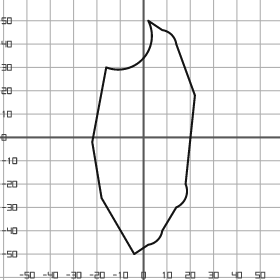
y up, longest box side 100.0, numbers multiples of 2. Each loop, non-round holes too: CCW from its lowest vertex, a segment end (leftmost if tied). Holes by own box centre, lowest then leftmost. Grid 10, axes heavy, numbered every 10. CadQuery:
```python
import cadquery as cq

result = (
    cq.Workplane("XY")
    .moveTo(-4.0, -50.0)
    .lineTo(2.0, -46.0)
    .threePointArc((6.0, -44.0), (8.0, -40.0))
    .lineTo(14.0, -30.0)
    .threePointArc((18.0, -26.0), (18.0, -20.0))
    .lineTo(22.0, 18.0)
    .lineTo(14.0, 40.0)
    .threePointArc((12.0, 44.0), (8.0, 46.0))
    .lineTo(2.0, 50.0)
    .threePointArc((0.0, 34.0), (-16.0, 30.0))
    .lineTo(-22.0, -2.0)
    .lineTo(-18.0, -26.0)
    .close()
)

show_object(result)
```